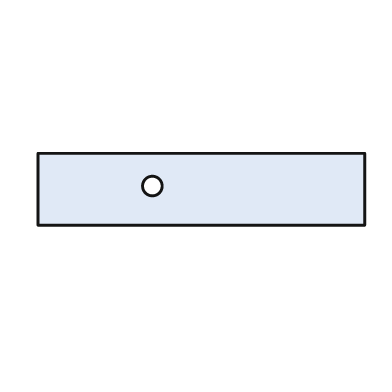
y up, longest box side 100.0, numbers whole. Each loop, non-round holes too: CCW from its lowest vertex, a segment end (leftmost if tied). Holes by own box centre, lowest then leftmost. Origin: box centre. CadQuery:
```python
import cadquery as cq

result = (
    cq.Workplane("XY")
    .moveTo(-50.0, -11.0)
    .lineTo(50.0, -11.0)
    .lineTo(50.0, 11.0)
    .lineTo(-50.0, 11.0)
    .close()
    .moveTo(-15.0, 1.0)
    .circle(3.0)
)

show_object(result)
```